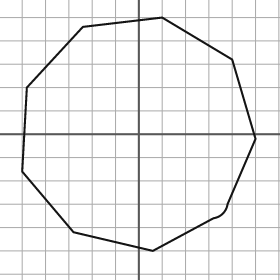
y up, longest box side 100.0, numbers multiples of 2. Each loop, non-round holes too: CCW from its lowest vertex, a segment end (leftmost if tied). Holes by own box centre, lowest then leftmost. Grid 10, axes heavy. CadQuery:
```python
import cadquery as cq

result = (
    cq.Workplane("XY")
    .moveTo(6.0, -50.0)
    .lineTo(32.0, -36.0)
    .threePointArc((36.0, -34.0), (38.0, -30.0))
    .lineTo(50.0, -2.0)
    .lineTo(40.0, 32.0)
    .lineTo(10.0, 50.0)
    .lineTo(-24.0, 46.0)
    .lineTo(-48.0, 20.0)
    .lineTo(-50.0, -16.0)
    .lineTo(-28.0, -42.0)
    .close()
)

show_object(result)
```